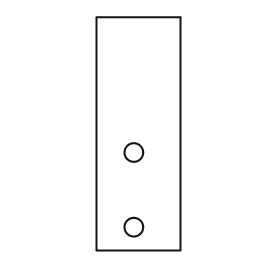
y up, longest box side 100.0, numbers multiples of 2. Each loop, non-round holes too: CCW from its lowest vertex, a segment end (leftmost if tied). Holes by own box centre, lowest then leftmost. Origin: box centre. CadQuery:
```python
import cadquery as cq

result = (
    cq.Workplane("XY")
    .moveTo(-18.0, -50.0)
    .lineTo(18.0, -50.0)
    .lineTo(18.0, 50.0)
    .lineTo(-18.0, 50.0)
    .close()
    .moveTo(-2.0, -40.0)
    .circle(4.0)
    .moveTo(-2.0, -8.0)
    .circle(4.0)
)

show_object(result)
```